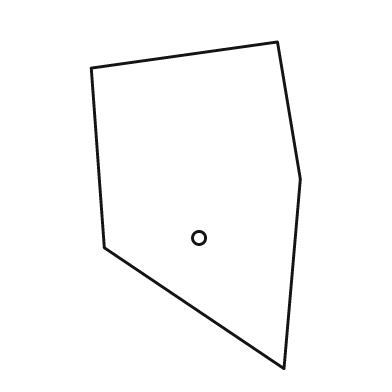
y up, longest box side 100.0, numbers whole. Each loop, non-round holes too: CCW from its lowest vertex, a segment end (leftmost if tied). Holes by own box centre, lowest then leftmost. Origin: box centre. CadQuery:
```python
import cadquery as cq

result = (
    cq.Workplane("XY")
    .moveTo(27.0, -50.0)
    .lineTo(32.0, 8.0)
    .lineTo(25.0, 50.0)
    .lineTo(-32.0, 42.0)
    .lineTo(-28.0, -13.0)
    .close()
    .moveTo(1.0, -10.0)
    .circle(2.0)
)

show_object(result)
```